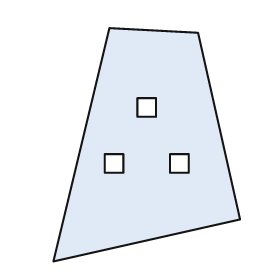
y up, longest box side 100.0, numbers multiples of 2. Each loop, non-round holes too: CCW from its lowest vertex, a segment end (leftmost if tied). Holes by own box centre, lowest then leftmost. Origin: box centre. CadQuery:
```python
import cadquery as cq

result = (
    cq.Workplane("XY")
    .moveTo(-40.0, -50.0)
    .lineTo(40.0, -32.0)
    .lineTo(22.0, 48.0)
    .lineTo(-16.0, 50.0)
    .close()
    .moveTo(-18.0, -12.0)
    .lineTo(-10.0, -12.0)
    .lineTo(-10.0, -4.0)
    .lineTo(-18.0, -4.0)
    .close()
    .moveTo(10.0, -12.0)
    .lineTo(18.0, -12.0)
    .lineTo(18.0, -4.0)
    .lineTo(10.0, -4.0)
    .close()
    .moveTo(-4.0, 12.0)
    .lineTo(4.0, 12.0)
    .lineTo(4.0, 20.0)
    .lineTo(-4.0, 20.0)
    .close()
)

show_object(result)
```